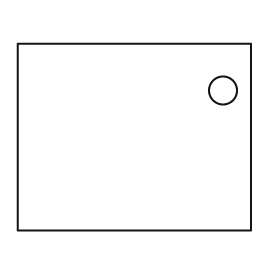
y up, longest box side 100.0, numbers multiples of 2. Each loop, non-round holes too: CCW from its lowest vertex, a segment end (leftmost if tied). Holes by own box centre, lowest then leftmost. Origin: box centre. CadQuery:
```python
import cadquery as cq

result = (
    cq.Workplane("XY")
    .moveTo(-50.0, -40.0)
    .lineTo(50.0, -40.0)
    .lineTo(50.0, 40.0)
    .lineTo(-50.0, 40.0)
    .close()
    .moveTo(38.0, 20.0)
    .circle(6.0)
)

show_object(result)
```